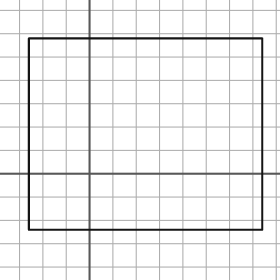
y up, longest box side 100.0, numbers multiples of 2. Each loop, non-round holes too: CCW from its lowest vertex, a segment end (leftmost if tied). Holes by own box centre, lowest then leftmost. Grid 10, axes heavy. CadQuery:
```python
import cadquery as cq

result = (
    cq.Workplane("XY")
    .moveTo(-26.0, -24.0)
    .lineTo(74.0, -24.0)
    .lineTo(74.0, 58.0)
    .lineTo(-26.0, 58.0)
    .close()
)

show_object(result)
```